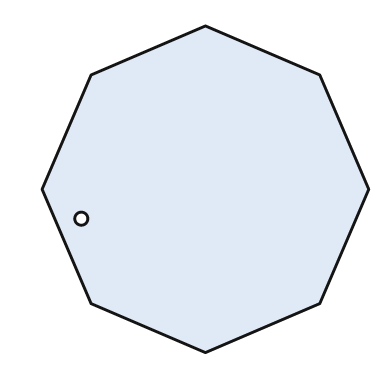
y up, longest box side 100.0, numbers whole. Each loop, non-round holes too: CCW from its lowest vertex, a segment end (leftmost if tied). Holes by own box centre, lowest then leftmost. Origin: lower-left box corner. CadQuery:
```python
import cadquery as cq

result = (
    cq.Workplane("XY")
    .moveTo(50.0, 0.0)
    .lineTo(85.0, 15.0)
    .lineTo(100.0, 50.0)
    .lineTo(85.0, 85.0)
    .lineTo(50.0, 100.0)
    .lineTo(15.0, 85.0)
    .lineTo(0.0, 50.0)
    .lineTo(15.0, 15.0)
    .close()
    .moveTo(12.0, 41.0)
    .circle(2.0)
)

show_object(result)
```